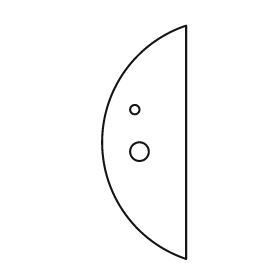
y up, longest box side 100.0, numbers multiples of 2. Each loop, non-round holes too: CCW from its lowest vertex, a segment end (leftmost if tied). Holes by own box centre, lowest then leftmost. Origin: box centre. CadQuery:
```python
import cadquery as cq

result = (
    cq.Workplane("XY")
    .moveTo(18.0, -50.0)
    .lineTo(18.0, 50.0)
    .threePointArc((-18.0, 0.0), (18.0, -50.0))
    .close()
    .moveTo(-2.0, -4.0)
    .circle(4.0)
    .moveTo(-4.0, 14.0)
    .circle(2.0)
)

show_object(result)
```